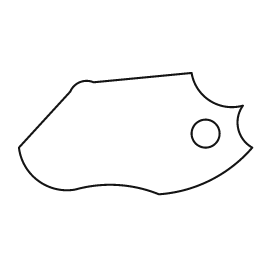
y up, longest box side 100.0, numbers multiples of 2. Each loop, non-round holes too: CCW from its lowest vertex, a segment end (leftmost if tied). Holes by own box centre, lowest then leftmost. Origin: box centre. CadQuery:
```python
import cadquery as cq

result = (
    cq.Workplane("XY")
    .moveTo(10.0, -26.0)
    .threePointArc((32.0, -20.0), (50.0, -6.0))
    .threePointArc((44.0, 2.0), (46.0, 12.0))
    .threePointArc((32.0, 14.0), (24.0, 26.0))
    .lineTo(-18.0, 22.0)
    .threePointArc((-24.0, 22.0), (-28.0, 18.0))
    .lineTo(-50.0, -6.0)
    .threePointArc((-42.0, -20.0), (-26.0, -24.0))
    .threePointArc((-8.0, -22.0), (10.0, -26.0))
    .close()
    .moveTo(30.0, 0.0)
    .circle(6.0)
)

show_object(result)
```